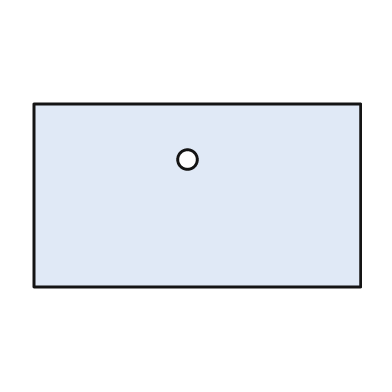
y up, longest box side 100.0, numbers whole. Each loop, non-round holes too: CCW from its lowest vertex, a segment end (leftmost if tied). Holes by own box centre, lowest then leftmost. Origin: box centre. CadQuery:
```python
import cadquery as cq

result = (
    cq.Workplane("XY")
    .moveTo(-50.0, -28.0)
    .lineTo(50.0, -28.0)
    .lineTo(50.0, 28.0)
    .lineTo(-50.0, 28.0)
    .close()
    .moveTo(-3.0, 11.0)
    .circle(3.0)
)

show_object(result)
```